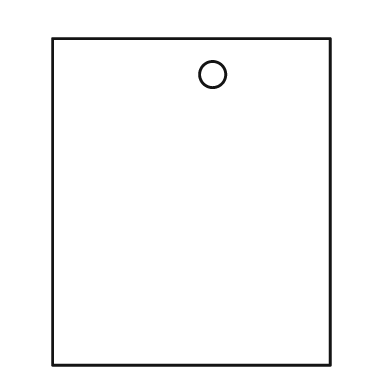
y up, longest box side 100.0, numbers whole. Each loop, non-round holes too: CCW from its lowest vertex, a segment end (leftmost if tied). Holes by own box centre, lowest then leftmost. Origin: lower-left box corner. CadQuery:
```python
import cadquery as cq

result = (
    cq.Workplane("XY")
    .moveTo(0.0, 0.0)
    .lineTo(85.0, 0.0)
    .lineTo(85.0, 100.0)
    .lineTo(0.0, 100.0)
    .close()
    .moveTo(49.0, 89.0)
    .circle(4.0)
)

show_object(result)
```